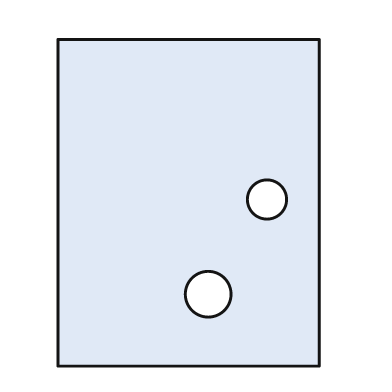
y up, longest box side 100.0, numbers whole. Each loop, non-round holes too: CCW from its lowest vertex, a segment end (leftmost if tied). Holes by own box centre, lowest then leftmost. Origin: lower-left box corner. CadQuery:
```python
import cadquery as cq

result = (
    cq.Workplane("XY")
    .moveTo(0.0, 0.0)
    .lineTo(80.0, 0.0)
    .lineTo(80.0, 100.0)
    .lineTo(0.0, 100.0)
    .close()
    .moveTo(46.0, 22.0)
    .circle(7.0)
    .moveTo(64.0, 51.0)
    .circle(6.0)
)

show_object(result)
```